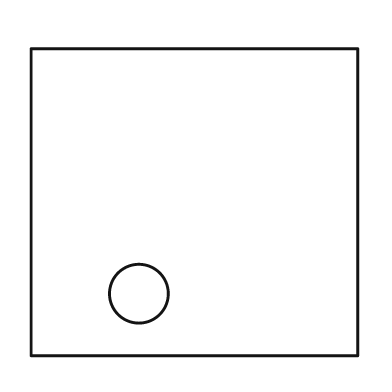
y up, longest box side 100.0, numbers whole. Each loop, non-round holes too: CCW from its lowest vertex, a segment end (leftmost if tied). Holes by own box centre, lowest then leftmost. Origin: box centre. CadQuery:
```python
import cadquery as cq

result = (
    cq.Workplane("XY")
    .moveTo(-50.0, -47.0)
    .lineTo(50.0, -47.0)
    .lineTo(50.0, 47.0)
    .lineTo(-50.0, 47.0)
    .close()
    .moveTo(-17.0, -28.0)
    .circle(9.0)
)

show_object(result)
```